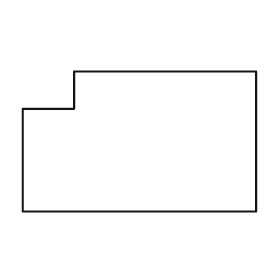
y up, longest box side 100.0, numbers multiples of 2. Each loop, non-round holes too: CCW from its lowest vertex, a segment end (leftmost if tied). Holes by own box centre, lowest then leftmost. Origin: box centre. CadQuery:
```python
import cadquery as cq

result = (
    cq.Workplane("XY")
    .moveTo(-50.0, -30.0)
    .lineTo(50.0, -30.0)
    .lineTo(50.0, 30.0)
    .lineTo(-28.0, 30.0)
    .lineTo(-28.0, 14.0)
    .lineTo(-50.0, 14.0)
    .close()
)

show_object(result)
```